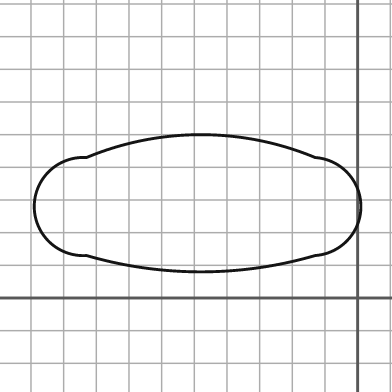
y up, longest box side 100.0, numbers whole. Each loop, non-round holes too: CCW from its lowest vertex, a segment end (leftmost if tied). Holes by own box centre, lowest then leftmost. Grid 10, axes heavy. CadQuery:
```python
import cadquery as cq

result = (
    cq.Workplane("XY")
    .moveTo(-83.0, 13.0)
    .threePointArc((-48.0, 8.0), (-13.0, 13.0))
    .threePointArc((1.0, 28.0), (-13.0, 43.0))
    .threePointArc((-48.0, 50.0), (-83.0, 43.0))
    .threePointArc((-99.0, 28.0), (-83.0, 13.0))
    .close()
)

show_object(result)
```